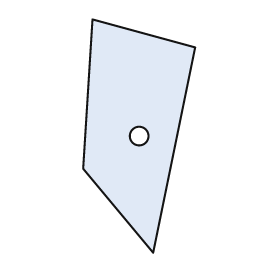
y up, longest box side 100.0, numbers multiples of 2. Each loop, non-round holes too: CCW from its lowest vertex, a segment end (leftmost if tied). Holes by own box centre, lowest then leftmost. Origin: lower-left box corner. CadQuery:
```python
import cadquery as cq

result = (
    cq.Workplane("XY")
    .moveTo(30.0, 0.0)
    .lineTo(48.0, 88.0)
    .lineTo(4.0, 100.0)
    .lineTo(0.0, 36.0)
    .close()
    .moveTo(24.0, 50.0)
    .circle(4.0)
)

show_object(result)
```